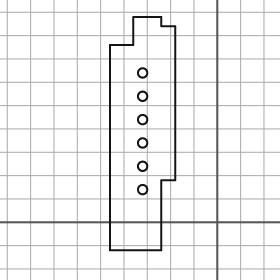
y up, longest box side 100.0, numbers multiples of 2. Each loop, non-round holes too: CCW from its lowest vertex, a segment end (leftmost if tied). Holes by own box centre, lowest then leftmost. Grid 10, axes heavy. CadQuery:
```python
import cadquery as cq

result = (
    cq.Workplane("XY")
    .moveTo(-46.0, -12.0)
    .lineTo(-24.0, -12.0)
    .lineTo(-24.0, 18.0)
    .lineTo(-18.0, 18.0)
    .lineTo(-18.0, 84.0)
    .lineTo(-24.0, 84.0)
    .lineTo(-24.0, 88.0)
    .lineTo(-36.0, 88.0)
    .lineTo(-36.0, 76.0)
    .lineTo(-46.0, 76.0)
    .close()
    .moveTo(-32.0, 14.0)
    .circle(2.0)
    .moveTo(-32.0, 24.0)
    .circle(2.0)
    .moveTo(-32.0, 34.0)
    .circle(2.0)
    .moveTo(-32.0, 44.0)
    .circle(2.0)
    .moveTo(-32.0, 54.0)
    .circle(2.0)
    .moveTo(-32.0, 64.0)
    .circle(2.0)
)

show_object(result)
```